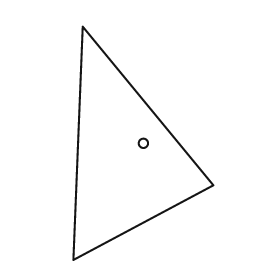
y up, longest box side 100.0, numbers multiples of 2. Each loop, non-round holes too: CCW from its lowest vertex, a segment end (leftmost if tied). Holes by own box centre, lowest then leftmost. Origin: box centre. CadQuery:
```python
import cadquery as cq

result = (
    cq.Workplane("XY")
    .moveTo(-30.0, -50.0)
    .lineTo(30.0, -18.0)
    .lineTo(-26.0, 50.0)
    .close()
    .moveTo(0.0, 0.0)
    .circle(2.0)
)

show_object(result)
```